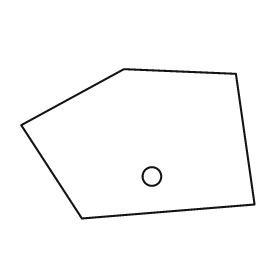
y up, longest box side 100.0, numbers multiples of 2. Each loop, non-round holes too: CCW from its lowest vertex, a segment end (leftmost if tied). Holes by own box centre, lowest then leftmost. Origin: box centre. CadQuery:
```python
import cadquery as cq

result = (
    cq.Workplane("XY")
    .moveTo(-24.0, -32.0)
    .lineTo(50.0, -26.0)
    .lineTo(42.0, 30.0)
    .lineTo(-6.0, 32.0)
    .lineTo(-50.0, 8.0)
    .close()
    .moveTo(6.0, -14.0)
    .circle(4.0)
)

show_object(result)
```